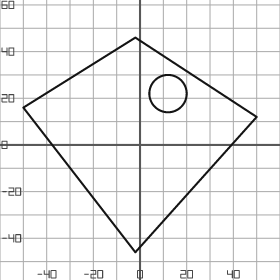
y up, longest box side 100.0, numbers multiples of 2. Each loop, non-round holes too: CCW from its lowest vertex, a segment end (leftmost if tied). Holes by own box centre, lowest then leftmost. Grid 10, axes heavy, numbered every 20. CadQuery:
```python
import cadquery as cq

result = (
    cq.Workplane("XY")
    .moveTo(-2.0, -46.0)
    .lineTo(50.0, 12.0)
    .lineTo(-2.0, 46.0)
    .lineTo(-50.0, 16.0)
    .close()
    .moveTo(12.0, 22.0)
    .circle(8.0)
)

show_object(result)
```